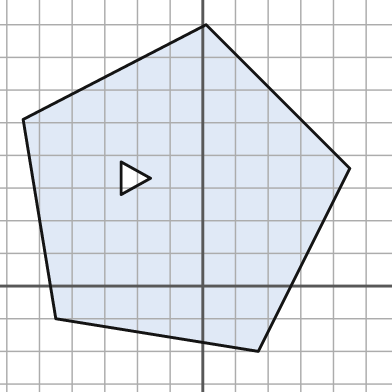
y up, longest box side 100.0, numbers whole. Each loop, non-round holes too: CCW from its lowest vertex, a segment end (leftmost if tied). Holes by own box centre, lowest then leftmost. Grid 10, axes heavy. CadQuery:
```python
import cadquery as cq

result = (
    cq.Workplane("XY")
    .moveTo(17.0, -20.0)
    .lineTo(45.0, 36.0)
    .lineTo(1.0, 80.0)
    .lineTo(-55.0, 51.0)
    .lineTo(-45.0, -10.0)
    .close()
    .moveTo(-25.0, 28.0)
    .lineTo(-16.0, 33.0)
    .lineTo(-25.0, 38.0)
    .close()
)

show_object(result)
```